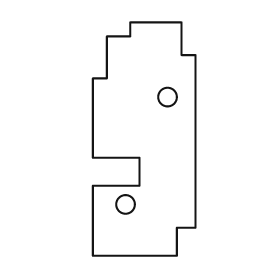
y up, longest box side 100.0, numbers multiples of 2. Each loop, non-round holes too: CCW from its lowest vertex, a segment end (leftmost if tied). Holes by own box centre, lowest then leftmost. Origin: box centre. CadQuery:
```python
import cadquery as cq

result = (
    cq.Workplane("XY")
    .moveTo(-22.0, -50.0)
    .lineTo(14.0, -50.0)
    .lineTo(14.0, -38.0)
    .lineTo(22.0, -38.0)
    .lineTo(22.0, 36.0)
    .lineTo(16.0, 36.0)
    .lineTo(16.0, 50.0)
    .lineTo(-6.0, 50.0)
    .lineTo(-6.0, 44.0)
    .lineTo(-16.0, 44.0)
    .lineTo(-16.0, 26.0)
    .lineTo(-22.0, 26.0)
    .lineTo(-22.0, -8.0)
    .lineTo(-2.0, -8.0)
    .lineTo(-2.0, -20.0)
    .lineTo(-22.0, -20.0)
    .close()
    .moveTo(-8.0, -28.0)
    .circle(4.0)
    .moveTo(10.0, 18.0)
    .circle(4.0)
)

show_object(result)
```